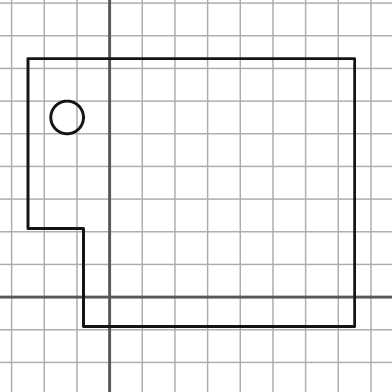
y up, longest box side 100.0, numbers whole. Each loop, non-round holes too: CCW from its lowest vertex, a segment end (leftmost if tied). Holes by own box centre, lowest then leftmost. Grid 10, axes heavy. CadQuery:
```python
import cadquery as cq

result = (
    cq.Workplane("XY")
    .moveTo(-8.0, -9.0)
    .lineTo(75.0, -9.0)
    .lineTo(75.0, 73.0)
    .lineTo(-25.0, 73.0)
    .lineTo(-25.0, 21.0)
    .lineTo(-8.0, 21.0)
    .close()
    .moveTo(-13.0, 55.0)
    .circle(5.0)
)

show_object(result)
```